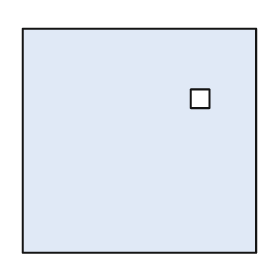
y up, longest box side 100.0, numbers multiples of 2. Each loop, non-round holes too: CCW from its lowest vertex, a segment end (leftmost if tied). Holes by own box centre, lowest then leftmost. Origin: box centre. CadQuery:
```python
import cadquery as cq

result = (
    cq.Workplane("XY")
    .moveTo(-50.0, -48.0)
    .lineTo(50.0, -48.0)
    .lineTo(50.0, 48.0)
    .lineTo(-50.0, 48.0)
    .close()
    .moveTo(22.0, 14.0)
    .lineTo(30.0, 14.0)
    .lineTo(30.0, 22.0)
    .lineTo(22.0, 22.0)
    .close()
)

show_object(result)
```